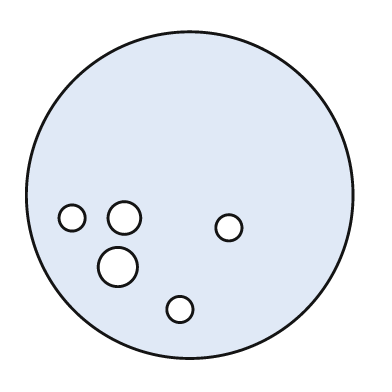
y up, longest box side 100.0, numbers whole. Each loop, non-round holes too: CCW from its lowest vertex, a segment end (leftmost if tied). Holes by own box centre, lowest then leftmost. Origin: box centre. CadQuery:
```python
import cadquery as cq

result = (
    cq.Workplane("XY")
    .moveTo(0.0, 0.0)
    .circle(50.0)
    .moveTo(-3.0, -35.0)
    .circle(4.0)
    .moveTo(-22.0, -22.0)
    .circle(6.0)
    .moveTo(12.0, -10.0)
    .circle(4.0)
    .moveTo(-36.0, -7.0)
    .circle(4.0)
    .moveTo(-20.0, -7.0)
    .circle(5.0)
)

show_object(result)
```